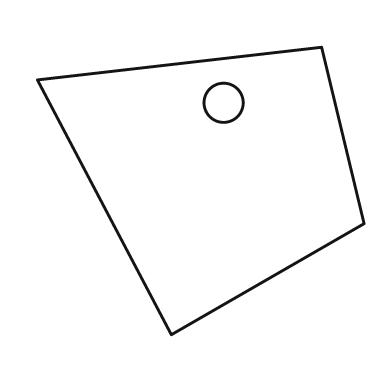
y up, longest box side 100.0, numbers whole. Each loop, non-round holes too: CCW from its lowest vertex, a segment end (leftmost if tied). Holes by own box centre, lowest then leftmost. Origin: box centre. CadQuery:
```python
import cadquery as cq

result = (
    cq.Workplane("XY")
    .moveTo(-9.0, -44.0)
    .lineTo(50.0, -10.0)
    .lineTo(37.0, 44.0)
    .lineTo(-50.0, 34.0)
    .close()
    .moveTo(7.0, 27.0)
    .circle(6.0)
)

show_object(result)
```